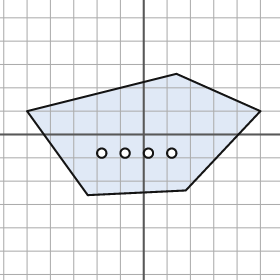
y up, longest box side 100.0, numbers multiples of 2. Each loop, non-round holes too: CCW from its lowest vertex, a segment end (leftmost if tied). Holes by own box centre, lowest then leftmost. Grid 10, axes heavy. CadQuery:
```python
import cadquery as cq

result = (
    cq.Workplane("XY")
    .moveTo(-24.0, -26.0)
    .lineTo(18.0, -24.0)
    .lineTo(50.0, 10.0)
    .lineTo(14.0, 26.0)
    .lineTo(-50.0, 10.0)
    .close()
    .moveTo(-18.0, -8.0)
    .circle(2.0)
    .moveTo(-8.0, -8.0)
    .circle(2.0)
    .moveTo(2.0, -8.0)
    .circle(2.0)
    .moveTo(12.0, -8.0)
    .circle(2.0)
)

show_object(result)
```